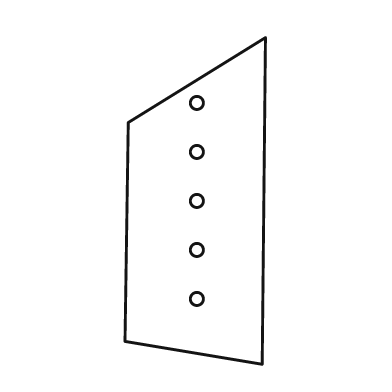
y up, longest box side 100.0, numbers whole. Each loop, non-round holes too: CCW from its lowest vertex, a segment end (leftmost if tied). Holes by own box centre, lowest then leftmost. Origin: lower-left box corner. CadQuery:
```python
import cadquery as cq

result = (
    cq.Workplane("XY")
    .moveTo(42.0, 0.0)
    .lineTo(43.0, 100.0)
    .lineTo(1.0, 74.0)
    .lineTo(0.0, 7.0)
    .close()
    .moveTo(22.0, 20.0)
    .circle(2.0)
    .moveTo(22.0, 35.0)
    .circle(2.0)
    .moveTo(22.0, 50.0)
    .circle(2.0)
    .moveTo(22.0, 65.0)
    .circle(2.0)
    .moveTo(22.0, 80.0)
    .circle(2.0)
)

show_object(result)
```